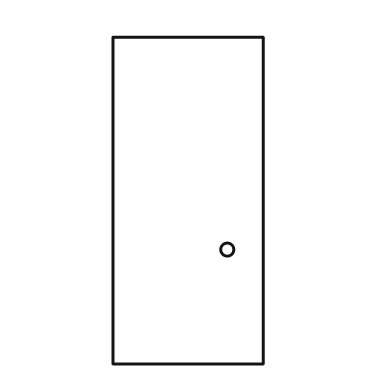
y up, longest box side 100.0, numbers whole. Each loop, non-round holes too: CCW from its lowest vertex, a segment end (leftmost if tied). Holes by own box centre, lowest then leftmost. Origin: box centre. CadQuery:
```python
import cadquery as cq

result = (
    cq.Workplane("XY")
    .moveTo(-23.0, -50.0)
    .lineTo(23.0, -50.0)
    .lineTo(23.0, 50.0)
    .lineTo(-23.0, 50.0)
    .close()
    .moveTo(12.0, -15.0)
    .circle(2.0)
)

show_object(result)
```